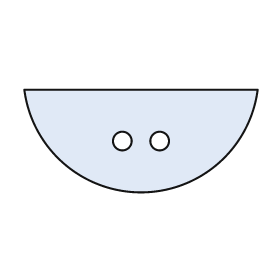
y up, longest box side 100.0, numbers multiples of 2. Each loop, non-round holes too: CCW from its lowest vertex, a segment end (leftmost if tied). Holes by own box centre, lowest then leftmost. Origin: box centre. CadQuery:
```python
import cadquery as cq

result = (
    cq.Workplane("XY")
    .moveTo(-50.0, 22.0)
    .threePointArc((0.0, -22.0), (50.0, 22.0))
    .close()
    .moveTo(-8.0, 0.0)
    .circle(4.0)
    .moveTo(8.0, 0.0)
    .circle(4.0)
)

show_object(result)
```